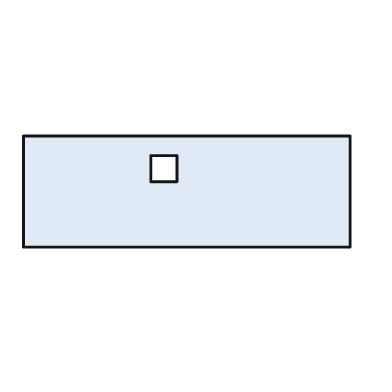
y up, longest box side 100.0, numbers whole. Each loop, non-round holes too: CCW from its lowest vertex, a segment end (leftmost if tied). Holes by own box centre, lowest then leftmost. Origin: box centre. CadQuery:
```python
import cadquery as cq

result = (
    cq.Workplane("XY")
    .moveTo(-50.0, -17.0)
    .lineTo(50.0, -17.0)
    .lineTo(50.0, 17.0)
    .lineTo(-50.0, 17.0)
    .close()
    .moveTo(-11.0, 3.0)
    .lineTo(-3.0, 3.0)
    .lineTo(-3.0, 11.0)
    .lineTo(-11.0, 11.0)
    .close()
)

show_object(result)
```